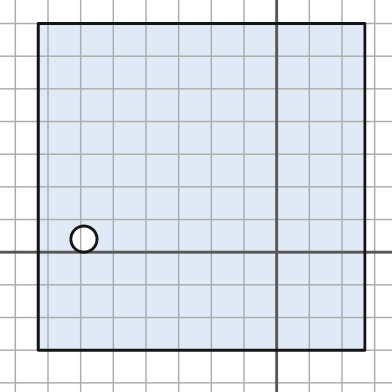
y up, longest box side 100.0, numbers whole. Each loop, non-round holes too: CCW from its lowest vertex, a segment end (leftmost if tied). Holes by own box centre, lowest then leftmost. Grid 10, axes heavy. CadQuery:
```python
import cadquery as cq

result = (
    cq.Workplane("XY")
    .moveTo(-73.0, -30.0)
    .lineTo(27.0, -30.0)
    .lineTo(27.0, 70.0)
    .lineTo(-73.0, 70.0)
    .close()
    .moveTo(-59.0, 4.0)
    .circle(4.0)
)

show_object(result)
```